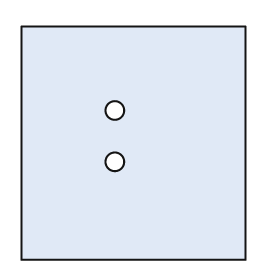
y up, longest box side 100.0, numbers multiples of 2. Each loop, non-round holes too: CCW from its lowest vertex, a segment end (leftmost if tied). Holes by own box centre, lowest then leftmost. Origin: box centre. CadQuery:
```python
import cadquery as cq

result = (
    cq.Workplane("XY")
    .moveTo(-48.0, -50.0)
    .lineTo(48.0, -50.0)
    .lineTo(48.0, 50.0)
    .lineTo(-48.0, 50.0)
    .close()
    .moveTo(-8.0, -8.0)
    .circle(4.0)
    .moveTo(-8.0, 14.0)
    .circle(4.0)
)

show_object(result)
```